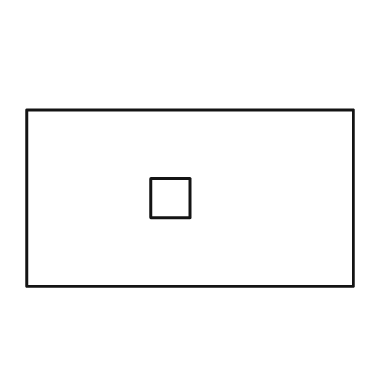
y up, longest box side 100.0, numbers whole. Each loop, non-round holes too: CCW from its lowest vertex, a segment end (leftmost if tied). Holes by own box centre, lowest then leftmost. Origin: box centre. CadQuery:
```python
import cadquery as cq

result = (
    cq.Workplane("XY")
    .moveTo(-50.0, -27.0)
    .lineTo(50.0, -27.0)
    .lineTo(50.0, 27.0)
    .lineTo(-50.0, 27.0)
    .close()
    .moveTo(-12.0, -6.0)
    .lineTo(0.0, -6.0)
    .lineTo(0.0, 6.0)
    .lineTo(-12.0, 6.0)
    .close()
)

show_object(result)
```